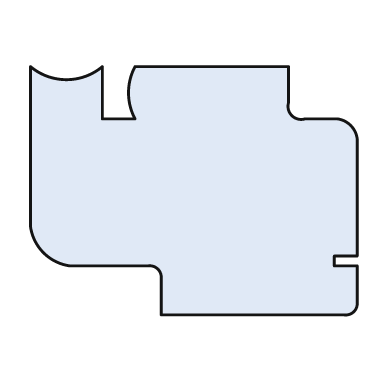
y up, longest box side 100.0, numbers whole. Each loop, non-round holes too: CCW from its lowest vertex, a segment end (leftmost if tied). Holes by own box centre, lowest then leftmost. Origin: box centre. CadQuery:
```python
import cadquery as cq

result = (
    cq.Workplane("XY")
    .moveTo(-10.0, -38.0)
    .lineTo(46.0, -38.0)
    .threePointArc((49.0, -37.0), (50.0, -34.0))
    .lineTo(50.0, -23.0)
    .lineTo(43.0, -23.0)
    .lineTo(43.0, -20.0)
    .lineTo(50.0, -20.0)
    .lineTo(50.0, 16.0)
    .threePointArc((48.0, 20.0), (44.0, 22.0))
    .lineTo(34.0, 22.0)
    .threePointArc((30.0, 23.0), (29.0, 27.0))
    .lineTo(29.0, 38.0)
    .lineTo(-18.0, 38.0)
    .threePointArc((-20.0, 30.0), (-18.0, 22.0))
    .lineTo(-28.0, 22.0)
    .lineTo(-28.0, 38.0)
    .threePointArc((-39.0, 34.0), (-50.0, 38.0))
    .lineTo(-50.0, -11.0)
    .threePointArc((-46.0, -19.0), (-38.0, -23.0))
    .lineTo(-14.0, -23.0)
    .threePointArc((-11.0, -24.0), (-10.0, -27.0))
    .close()
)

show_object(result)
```